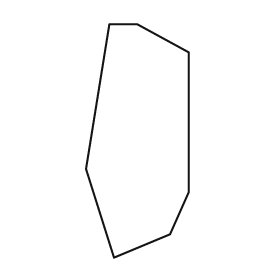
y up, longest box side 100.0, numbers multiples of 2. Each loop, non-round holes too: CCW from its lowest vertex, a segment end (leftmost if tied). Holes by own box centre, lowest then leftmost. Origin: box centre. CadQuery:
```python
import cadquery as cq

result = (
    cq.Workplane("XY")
    .moveTo(-10.0, -50.0)
    .lineTo(14.0, -40.0)
    .lineTo(22.0, -22.0)
    .lineTo(22.0, 38.0)
    .lineTo(0.0, 50.0)
    .lineTo(-12.0, 50.0)
    .lineTo(-22.0, -12.0)
    .close()
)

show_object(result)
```